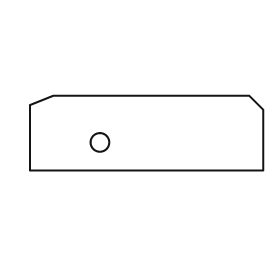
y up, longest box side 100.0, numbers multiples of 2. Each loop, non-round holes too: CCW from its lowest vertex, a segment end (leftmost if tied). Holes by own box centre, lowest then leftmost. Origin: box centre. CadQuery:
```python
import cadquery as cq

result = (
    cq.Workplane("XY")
    .moveTo(-50.0, -16.0)
    .lineTo(50.0, -16.0)
    .lineTo(50.0, 10.0)
    .lineTo(44.0, 16.0)
    .lineTo(-40.0, 16.0)
    .lineTo(-50.0, 12.0)
    .close()
    .moveTo(-20.0, -4.0)
    .circle(4.0)
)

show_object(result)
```